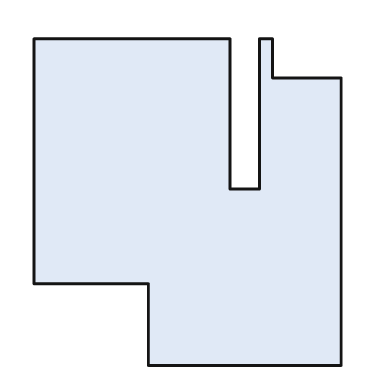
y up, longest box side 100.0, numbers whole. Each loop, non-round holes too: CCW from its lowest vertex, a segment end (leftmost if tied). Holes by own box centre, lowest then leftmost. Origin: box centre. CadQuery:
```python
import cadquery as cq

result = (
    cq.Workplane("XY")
    .moveTo(-12.0, -50.0)
    .lineTo(47.0, -50.0)
    .lineTo(47.0, 38.0)
    .lineTo(26.0, 38.0)
    .lineTo(26.0, 50.0)
    .lineTo(22.0, 50.0)
    .lineTo(22.0, 4.0)
    .lineTo(13.0, 4.0)
    .lineTo(13.0, 50.0)
    .lineTo(-47.0, 50.0)
    .lineTo(-47.0, -25.0)
    .lineTo(-12.0, -25.0)
    .close()
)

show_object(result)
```